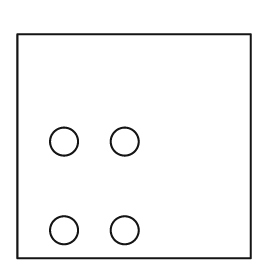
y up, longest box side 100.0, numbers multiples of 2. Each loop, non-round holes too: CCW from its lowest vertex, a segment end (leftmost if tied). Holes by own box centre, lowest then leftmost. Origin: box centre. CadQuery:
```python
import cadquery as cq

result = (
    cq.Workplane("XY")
    .moveTo(-50.0, -48.0)
    .lineTo(50.0, -48.0)
    .lineTo(50.0, 48.0)
    .lineTo(-50.0, 48.0)
    .close()
    .moveTo(-30.0, -36.0)
    .circle(6.0)
    .moveTo(-4.0, -36.0)
    .circle(6.0)
    .moveTo(-30.0, 2.0)
    .circle(6.0)
    .moveTo(-4.0, 2.0)
    .circle(6.0)
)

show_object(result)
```